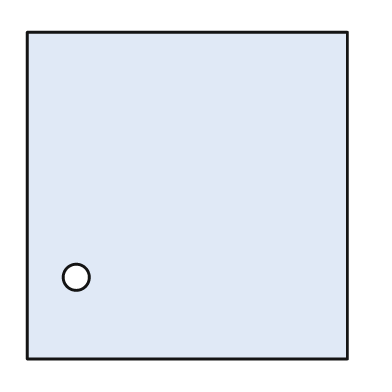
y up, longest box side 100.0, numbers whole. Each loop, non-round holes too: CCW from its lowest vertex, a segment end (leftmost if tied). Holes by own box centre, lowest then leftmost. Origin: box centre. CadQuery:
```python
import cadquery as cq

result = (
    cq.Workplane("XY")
    .moveTo(-49.0, -50.0)
    .lineTo(49.0, -50.0)
    .lineTo(49.0, 50.0)
    .lineTo(-49.0, 50.0)
    .close()
    .moveTo(-34.0, -25.0)
    .circle(4.0)
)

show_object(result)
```